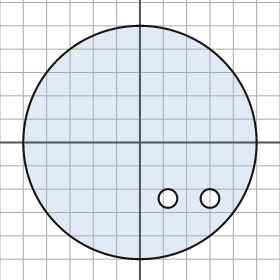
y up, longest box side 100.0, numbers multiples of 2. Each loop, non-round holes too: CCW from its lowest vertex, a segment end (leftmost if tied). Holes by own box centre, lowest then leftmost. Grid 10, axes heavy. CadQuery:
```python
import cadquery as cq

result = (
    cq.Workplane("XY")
    .moveTo(0.0, 0.0)
    .circle(50.0)
    .moveTo(12.0, -24.0)
    .circle(4.0)
    .moveTo(30.0, -24.0)
    .circle(4.0)
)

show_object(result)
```